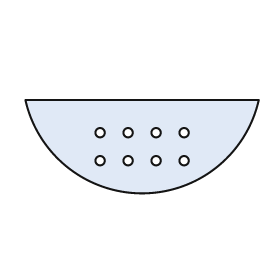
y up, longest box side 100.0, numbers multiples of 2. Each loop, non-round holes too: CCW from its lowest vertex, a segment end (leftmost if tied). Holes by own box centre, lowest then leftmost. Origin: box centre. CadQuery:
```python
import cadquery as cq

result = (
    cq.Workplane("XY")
    .moveTo(-50.0, 20.0)
    .threePointArc((0.0, -20.0), (50.0, 20.0))
    .close()
    .moveTo(-18.0, -6.0)
    .circle(2.0)
    .moveTo(-6.0, -6.0)
    .circle(2.0)
    .moveTo(6.0, -6.0)
    .circle(2.0)
    .moveTo(18.0, -6.0)
    .circle(2.0)
    .moveTo(-18.0, 6.0)
    .circle(2.0)
    .moveTo(-6.0, 6.0)
    .circle(2.0)
    .moveTo(6.0, 6.0)
    .circle(2.0)
    .moveTo(18.0, 6.0)
    .circle(2.0)
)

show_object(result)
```